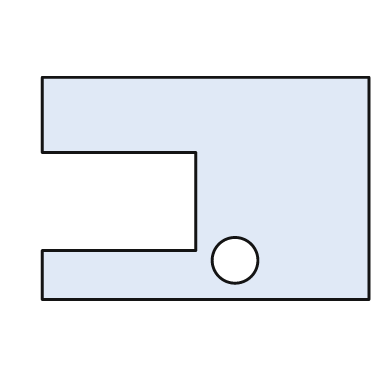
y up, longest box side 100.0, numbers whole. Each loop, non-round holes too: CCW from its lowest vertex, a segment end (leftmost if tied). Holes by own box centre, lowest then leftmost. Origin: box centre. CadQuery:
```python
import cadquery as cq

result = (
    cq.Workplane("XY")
    .moveTo(-50.0, -34.0)
    .lineTo(50.0, -34.0)
    .lineTo(50.0, 34.0)
    .lineTo(-50.0, 34.0)
    .lineTo(-50.0, 11.0)
    .lineTo(-3.0, 11.0)
    .lineTo(-3.0, -19.0)
    .lineTo(-50.0, -19.0)
    .close()
    .moveTo(9.0, -22.0)
    .circle(7.0)
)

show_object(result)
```